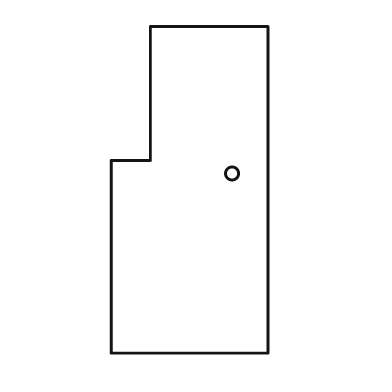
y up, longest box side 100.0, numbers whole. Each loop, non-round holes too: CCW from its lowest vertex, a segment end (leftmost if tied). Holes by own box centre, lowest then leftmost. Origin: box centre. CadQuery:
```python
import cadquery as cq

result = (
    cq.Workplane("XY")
    .moveTo(-24.0, -50.0)
    .lineTo(24.0, -50.0)
    .lineTo(24.0, 50.0)
    .lineTo(-12.0, 50.0)
    .lineTo(-12.0, 9.0)
    .lineTo(-24.0, 9.0)
    .close()
    .moveTo(13.0, 5.0)
    .circle(2.0)
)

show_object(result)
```